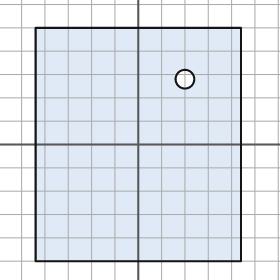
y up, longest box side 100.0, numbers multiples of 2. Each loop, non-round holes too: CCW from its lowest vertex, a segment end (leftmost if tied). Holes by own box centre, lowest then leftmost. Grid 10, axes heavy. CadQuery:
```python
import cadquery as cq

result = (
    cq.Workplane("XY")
    .moveTo(-44.0, -50.0)
    .lineTo(44.0, -50.0)
    .lineTo(44.0, 50.0)
    .lineTo(-44.0, 50.0)
    .close()
    .moveTo(20.0, 28.0)
    .circle(4.0)
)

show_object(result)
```